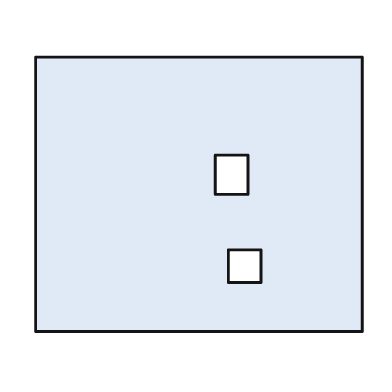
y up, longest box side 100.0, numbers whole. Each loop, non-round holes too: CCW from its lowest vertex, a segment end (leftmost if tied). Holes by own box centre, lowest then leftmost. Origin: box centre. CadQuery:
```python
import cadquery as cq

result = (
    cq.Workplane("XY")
    .moveTo(-50.0, -42.0)
    .lineTo(50.0, -42.0)
    .lineTo(50.0, 42.0)
    .lineTo(-50.0, 42.0)
    .close()
    .moveTo(9.0, -27.0)
    .lineTo(19.0, -27.0)
    .lineTo(19.0, -17.0)
    .lineTo(9.0, -17.0)
    .close()
    .moveTo(5.0, 0.0)
    .lineTo(15.0, 0.0)
    .lineTo(15.0, 12.0)
    .lineTo(5.0, 12.0)
    .close()
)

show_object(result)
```